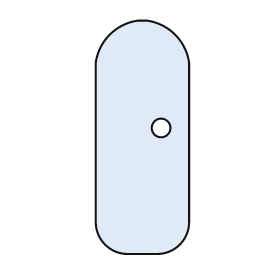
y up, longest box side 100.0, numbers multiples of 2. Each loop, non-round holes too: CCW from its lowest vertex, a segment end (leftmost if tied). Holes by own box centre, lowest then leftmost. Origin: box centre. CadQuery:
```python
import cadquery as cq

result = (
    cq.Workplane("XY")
    .moveTo(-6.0, -50.0)
    .lineTo(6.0, -50.0)
    .threePointArc((16.0, -46.0), (20.0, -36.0))
    .lineTo(20.0, 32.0)
    .threePointArc((14.0, 44.0), (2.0, 50.0))
    .lineTo(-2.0, 50.0)
    .threePointArc((-14.0, 44.0), (-20.0, 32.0))
    .lineTo(-20.0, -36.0)
    .threePointArc((-16.0, -46.0), (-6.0, -50.0))
    .close()
    .moveTo(8.0, 4.0)
    .circle(4.0)
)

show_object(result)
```